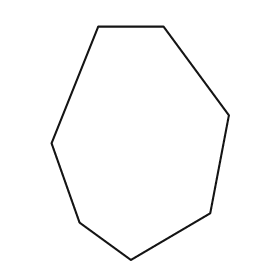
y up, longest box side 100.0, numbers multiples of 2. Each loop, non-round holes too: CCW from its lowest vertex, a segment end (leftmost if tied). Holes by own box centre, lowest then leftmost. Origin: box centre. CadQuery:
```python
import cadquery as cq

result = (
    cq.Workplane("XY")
    .moveTo(-4.0, -50.0)
    .lineTo(30.0, -30.0)
    .lineTo(38.0, 12.0)
    .lineTo(10.0, 50.0)
    .lineTo(-18.0, 50.0)
    .lineTo(-38.0, 0.0)
    .lineTo(-26.0, -34.0)
    .close()
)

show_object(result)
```